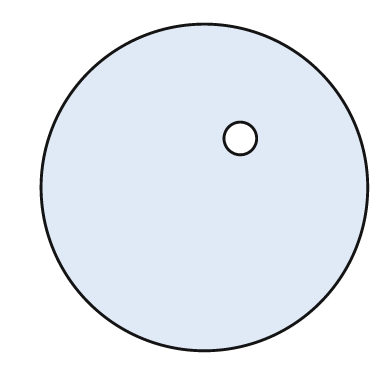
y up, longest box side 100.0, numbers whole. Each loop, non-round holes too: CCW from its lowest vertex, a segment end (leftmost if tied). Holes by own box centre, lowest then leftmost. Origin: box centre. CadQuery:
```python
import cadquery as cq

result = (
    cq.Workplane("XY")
    .moveTo(0.0, 0.0)
    .circle(50.0)
    .moveTo(11.0, 15.0)
    .circle(5.0)
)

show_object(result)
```